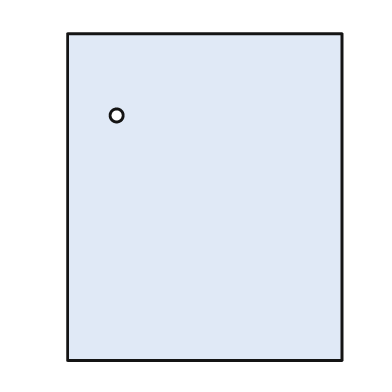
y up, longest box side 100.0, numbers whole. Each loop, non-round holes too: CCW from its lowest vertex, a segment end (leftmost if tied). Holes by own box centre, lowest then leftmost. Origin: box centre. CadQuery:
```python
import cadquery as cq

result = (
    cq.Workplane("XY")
    .moveTo(-42.0, -50.0)
    .lineTo(42.0, -50.0)
    .lineTo(42.0, 50.0)
    .lineTo(-42.0, 50.0)
    .close()
    .moveTo(-27.0, 25.0)
    .circle(2.0)
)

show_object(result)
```